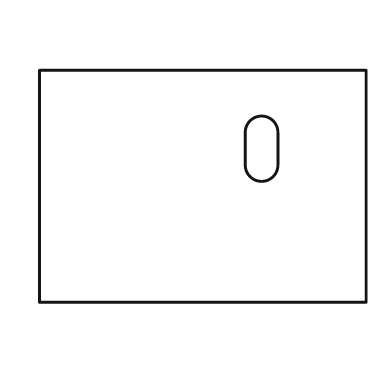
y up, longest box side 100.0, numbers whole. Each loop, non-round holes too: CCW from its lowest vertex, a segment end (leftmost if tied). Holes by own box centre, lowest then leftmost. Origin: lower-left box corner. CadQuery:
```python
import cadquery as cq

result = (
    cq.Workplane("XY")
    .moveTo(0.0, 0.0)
    .lineTo(100.0, 0.0)
    .lineTo(100.0, 71.0)
    .lineTo(0.0, 71.0)
    .close()
    .moveTo(63.0, 42.0)
    .threePointArc((68.0, 37.0), (73.0, 42.0))
    .lineTo(73.0, 52.0)
    .threePointArc((68.0, 57.0), (63.0, 52.0))
    .close()
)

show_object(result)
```